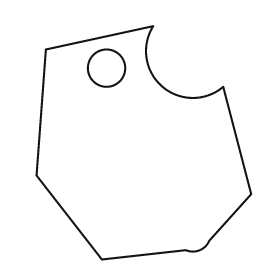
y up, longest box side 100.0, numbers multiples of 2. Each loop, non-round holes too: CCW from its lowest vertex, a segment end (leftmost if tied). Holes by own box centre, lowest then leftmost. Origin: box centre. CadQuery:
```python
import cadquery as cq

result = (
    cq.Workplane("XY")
    .moveTo(-18.0, -50.0)
    .lineTo(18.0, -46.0)
    .threePointArc((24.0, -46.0), (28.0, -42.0))
    .lineTo(46.0, -22.0)
    .lineTo(34.0, 24.0)
    .threePointArc((8.0, 24.0), (4.0, 50.0))
    .lineTo(-42.0, 40.0)
    .lineTo(-46.0, -14.0)
    .close()
    .moveTo(-16.0, 32.0)
    .circle(8.0)
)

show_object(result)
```